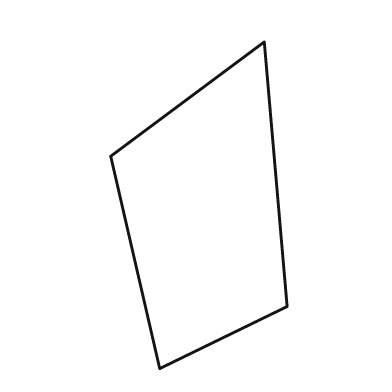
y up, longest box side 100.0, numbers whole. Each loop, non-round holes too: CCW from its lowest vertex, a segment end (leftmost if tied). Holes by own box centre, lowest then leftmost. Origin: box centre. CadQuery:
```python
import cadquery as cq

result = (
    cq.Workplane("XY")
    .moveTo(-12.0, -50.0)
    .lineTo(27.0, -31.0)
    .lineTo(20.0, 50.0)
    .lineTo(-27.0, 15.0)
    .close()
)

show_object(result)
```